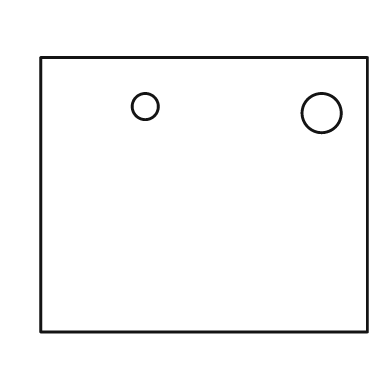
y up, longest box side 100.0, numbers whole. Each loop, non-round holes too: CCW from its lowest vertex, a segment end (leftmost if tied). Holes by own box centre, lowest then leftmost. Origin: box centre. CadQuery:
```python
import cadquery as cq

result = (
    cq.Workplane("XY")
    .moveTo(-50.0, -42.0)
    .lineTo(50.0, -42.0)
    .lineTo(50.0, 42.0)
    .lineTo(-50.0, 42.0)
    .close()
    .moveTo(36.0, 25.0)
    .circle(6.0)
    .moveTo(-18.0, 27.0)
    .circle(4.0)
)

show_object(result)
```